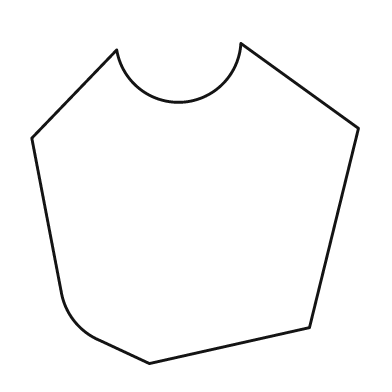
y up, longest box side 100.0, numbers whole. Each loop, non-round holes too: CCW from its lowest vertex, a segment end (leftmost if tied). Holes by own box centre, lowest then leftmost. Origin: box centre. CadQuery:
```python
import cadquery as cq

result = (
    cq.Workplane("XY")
    .moveTo(-14.0, -49.0)
    .lineTo(35.0, -38.0)
    .lineTo(50.0, 23.0)
    .lineTo(14.0, 49.0)
    .threePointArc((-4.0, 31.0), (-24.0, 47.0))
    .lineTo(-50.0, 20.0)
    .lineTo(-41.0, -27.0)
    .threePointArc((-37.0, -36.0), (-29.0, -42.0))
    .close()
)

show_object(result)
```